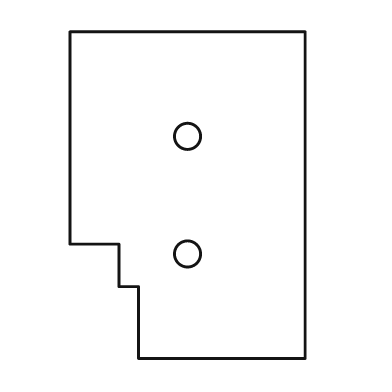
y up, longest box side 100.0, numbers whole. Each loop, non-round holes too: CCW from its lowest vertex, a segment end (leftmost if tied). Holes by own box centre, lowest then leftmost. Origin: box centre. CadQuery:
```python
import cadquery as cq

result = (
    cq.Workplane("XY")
    .moveTo(-15.0, -50.0)
    .lineTo(36.0, -50.0)
    .lineTo(36.0, 50.0)
    .lineTo(-36.0, 50.0)
    .lineTo(-36.0, -15.0)
    .lineTo(-21.0, -15.0)
    .lineTo(-21.0, -28.0)
    .lineTo(-15.0, -28.0)
    .close()
    .moveTo(0.0, -18.0)
    .circle(4.0)
    .moveTo(0.0, 18.0)
    .circle(4.0)
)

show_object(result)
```